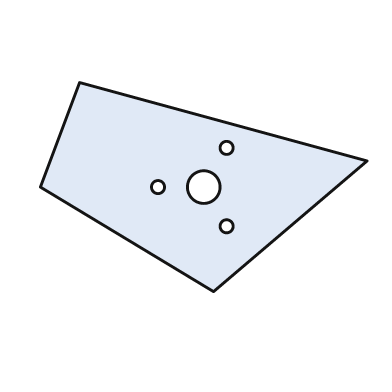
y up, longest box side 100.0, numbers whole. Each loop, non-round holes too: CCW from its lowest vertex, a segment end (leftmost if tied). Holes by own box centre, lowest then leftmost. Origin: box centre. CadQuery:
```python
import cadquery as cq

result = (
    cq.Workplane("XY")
    .moveTo(3.0, -32.0)
    .lineTo(50.0, 8.0)
    .lineTo(-38.0, 32.0)
    .lineTo(-50.0, 0.0)
    .close()
    .moveTo(7.0, -12.0)
    .circle(2.0)
    .moveTo(-14.0, 0.0)
    .circle(2.0)
    .moveTo(0.0, 0.0)
    .circle(5.0)
    .moveTo(7.0, 12.0)
    .circle(2.0)
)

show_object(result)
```